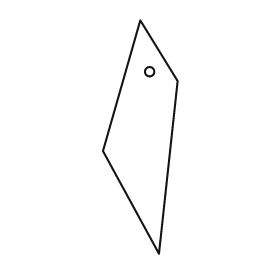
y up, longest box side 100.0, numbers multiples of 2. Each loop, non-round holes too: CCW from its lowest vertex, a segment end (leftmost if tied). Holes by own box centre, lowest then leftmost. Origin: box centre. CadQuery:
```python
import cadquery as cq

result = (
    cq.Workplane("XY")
    .moveTo(8.0, -50.0)
    .lineTo(16.0, 24.0)
    .lineTo(0.0, 50.0)
    .lineTo(-16.0, -6.0)
    .close()
    .moveTo(4.0, 28.0)
    .circle(2.0)
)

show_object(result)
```